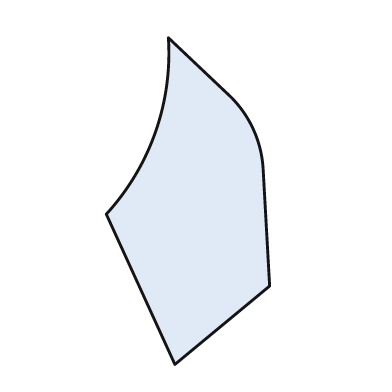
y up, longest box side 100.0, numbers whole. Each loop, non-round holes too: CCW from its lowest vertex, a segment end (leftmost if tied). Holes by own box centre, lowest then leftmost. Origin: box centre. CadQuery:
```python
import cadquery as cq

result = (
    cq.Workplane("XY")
    .moveTo(-4.0, -50.0)
    .lineTo(25.0, -26.0)
    .lineTo(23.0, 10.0)
    .threePointArc((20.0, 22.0), (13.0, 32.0))
    .lineTo(-6.0, 50.0)
    .threePointArc((-10.0, 21.0), (-25.0, -4.0))
    .close()
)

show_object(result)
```